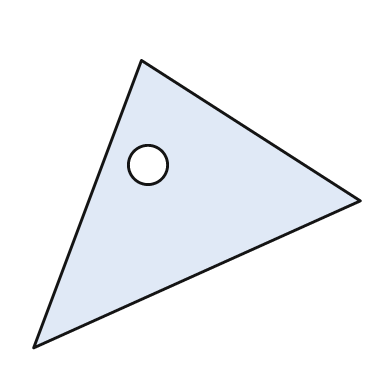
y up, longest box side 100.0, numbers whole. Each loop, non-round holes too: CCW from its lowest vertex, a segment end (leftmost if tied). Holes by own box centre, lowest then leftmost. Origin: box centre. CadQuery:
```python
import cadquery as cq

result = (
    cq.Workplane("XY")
    .moveTo(-50.0, -44.0)
    .lineTo(50.0, 1.0)
    .lineTo(-17.0, 44.0)
    .close()
    .moveTo(-15.0, 12.0)
    .circle(6.0)
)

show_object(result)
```